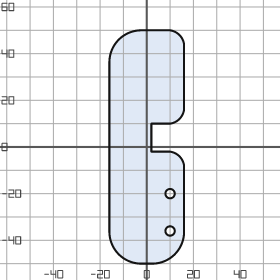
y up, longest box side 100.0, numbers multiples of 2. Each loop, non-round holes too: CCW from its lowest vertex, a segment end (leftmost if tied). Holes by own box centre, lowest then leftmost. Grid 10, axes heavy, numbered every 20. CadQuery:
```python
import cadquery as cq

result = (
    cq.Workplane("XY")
    .moveTo(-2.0, -50.0)
    .lineTo(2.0, -50.0)
    .threePointArc((12.0, -46.0), (16.0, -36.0))
    .lineTo(16.0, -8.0)
    .threePointArc((14.0, -4.0), (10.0, -2.0))
    .lineTo(2.0, -2.0)
    .lineTo(2.0, 10.0)
    .lineTo(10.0, 10.0)
    .threePointArc((14.0, 12.0), (16.0, 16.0))
    .lineTo(16.0, 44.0)
    .threePointArc((14.0, 48.0), (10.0, 50.0))
    .lineTo(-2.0, 50.0)
    .threePointArc((-12.0, 46.0), (-16.0, 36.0))
    .lineTo(-16.0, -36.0)
    .threePointArc((-12.0, -46.0), (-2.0, -50.0))
    .close()
    .moveTo(10.0, -36.0)
    .circle(2.0)
    .moveTo(10.0, -20.0)
    .circle(2.0)
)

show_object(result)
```